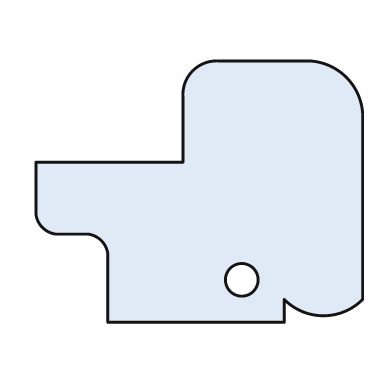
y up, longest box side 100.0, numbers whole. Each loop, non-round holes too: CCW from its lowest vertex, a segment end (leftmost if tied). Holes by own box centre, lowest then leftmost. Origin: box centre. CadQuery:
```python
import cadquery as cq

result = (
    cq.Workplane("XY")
    .moveTo(-28.0, -40.0)
    .lineTo(26.0, -40.0)
    .lineTo(26.0, -33.0)
    .threePointArc((38.0, -38.0), (50.0, -33.0))
    .lineTo(50.0, 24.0)
    .threePointArc((45.0, 35.0), (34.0, 40.0))
    .lineTo(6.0, 40.0)
    .threePointArc((-2.0, 37.0), (-5.0, 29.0))
    .lineTo(-5.0, 9.0)
    .lineTo(-50.0, 9.0)
    .lineTo(-50.0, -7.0)
    .threePointArc((-48.0, -11.0), (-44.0, -13.0))
    .lineTo(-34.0, -13.0)
    .threePointArc((-30.0, -15.0), (-28.0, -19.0))
    .close()
    .moveTo(13.0, -27.0)
    .circle(5.0)
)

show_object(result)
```